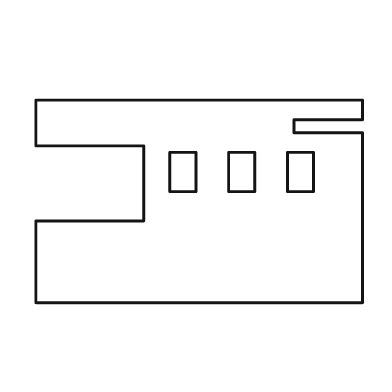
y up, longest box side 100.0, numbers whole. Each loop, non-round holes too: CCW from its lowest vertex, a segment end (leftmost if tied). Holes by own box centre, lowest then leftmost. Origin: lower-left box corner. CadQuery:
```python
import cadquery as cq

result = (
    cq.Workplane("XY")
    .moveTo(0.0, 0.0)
    .lineTo(100.0, 0.0)
    .lineTo(100.0, 52.0)
    .lineTo(79.0, 52.0)
    .lineTo(79.0, 56.0)
    .lineTo(100.0, 56.0)
    .lineTo(100.0, 62.0)
    .lineTo(0.0, 62.0)
    .lineTo(0.0, 48.0)
    .lineTo(33.0, 48.0)
    .lineTo(33.0, 25.0)
    .lineTo(0.0, 25.0)
    .close()
    .moveTo(41.0, 34.0)
    .lineTo(49.0, 34.0)
    .lineTo(49.0, 46.0)
    .lineTo(41.0, 46.0)
    .close()
    .moveTo(59.0, 34.0)
    .lineTo(67.0, 34.0)
    .lineTo(67.0, 46.0)
    .lineTo(59.0, 46.0)
    .close()
    .moveTo(77.0, 34.0)
    .lineTo(85.0, 34.0)
    .lineTo(85.0, 46.0)
    .lineTo(77.0, 46.0)
    .close()
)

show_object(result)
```